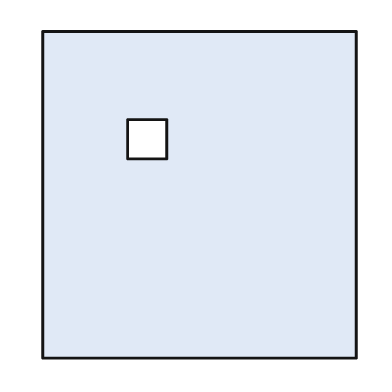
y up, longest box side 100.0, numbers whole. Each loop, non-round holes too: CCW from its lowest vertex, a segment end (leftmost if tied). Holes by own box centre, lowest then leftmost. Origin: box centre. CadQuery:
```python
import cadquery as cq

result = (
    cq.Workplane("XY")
    .moveTo(-48.0, -50.0)
    .lineTo(48.0, -50.0)
    .lineTo(48.0, 50.0)
    .lineTo(-48.0, 50.0)
    .close()
    .moveTo(-22.0, 11.0)
    .lineTo(-10.0, 11.0)
    .lineTo(-10.0, 23.0)
    .lineTo(-22.0, 23.0)
    .close()
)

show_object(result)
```